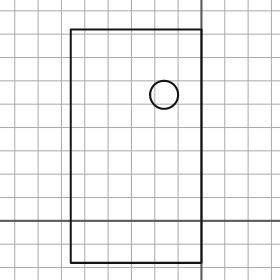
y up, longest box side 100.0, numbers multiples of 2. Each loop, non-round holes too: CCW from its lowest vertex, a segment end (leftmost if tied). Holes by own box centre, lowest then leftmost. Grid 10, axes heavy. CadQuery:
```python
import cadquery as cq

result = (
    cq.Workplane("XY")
    .moveTo(-56.0, -18.0)
    .lineTo(0.0, -18.0)
    .lineTo(0.0, 82.0)
    .lineTo(-56.0, 82.0)
    .close()
    .moveTo(-16.0, 54.0)
    .circle(6.0)
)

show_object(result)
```